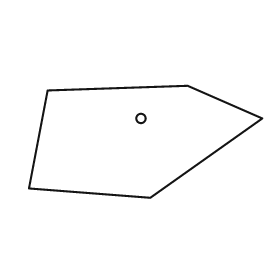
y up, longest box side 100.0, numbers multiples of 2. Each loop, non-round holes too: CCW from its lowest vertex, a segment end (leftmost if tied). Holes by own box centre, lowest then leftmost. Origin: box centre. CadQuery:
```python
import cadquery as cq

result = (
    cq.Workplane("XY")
    .moveTo(2.0, -24.0)
    .lineTo(50.0, 10.0)
    .lineTo(18.0, 24.0)
    .lineTo(-42.0, 22.0)
    .lineTo(-50.0, -20.0)
    .close()
    .moveTo(-2.0, 10.0)
    .circle(2.0)
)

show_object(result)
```